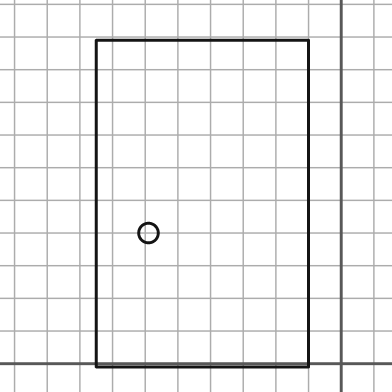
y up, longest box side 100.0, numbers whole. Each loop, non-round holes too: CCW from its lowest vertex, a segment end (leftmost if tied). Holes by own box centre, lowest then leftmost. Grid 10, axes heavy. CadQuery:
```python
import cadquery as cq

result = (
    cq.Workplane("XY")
    .moveTo(-75.0, -1.0)
    .lineTo(-10.0, -1.0)
    .lineTo(-10.0, 99.0)
    .lineTo(-75.0, 99.0)
    .close()
    .moveTo(-59.0, 40.0)
    .circle(3.0)
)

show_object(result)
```